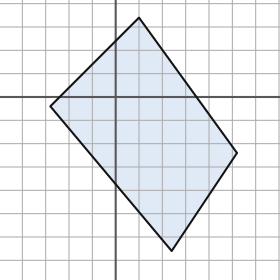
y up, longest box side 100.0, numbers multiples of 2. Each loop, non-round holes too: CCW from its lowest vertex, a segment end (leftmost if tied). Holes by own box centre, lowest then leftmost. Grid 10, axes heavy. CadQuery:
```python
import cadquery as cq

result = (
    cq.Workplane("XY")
    .moveTo(24.0, -66.0)
    .lineTo(52.0, -24.0)
    .lineTo(10.0, 34.0)
    .lineTo(-28.0, -4.0)
    .close()
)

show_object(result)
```